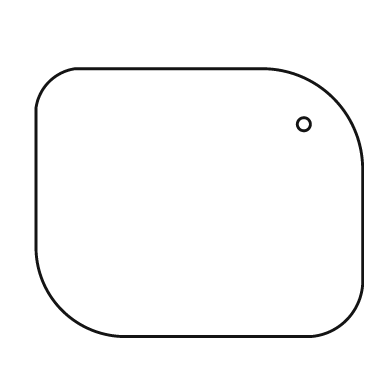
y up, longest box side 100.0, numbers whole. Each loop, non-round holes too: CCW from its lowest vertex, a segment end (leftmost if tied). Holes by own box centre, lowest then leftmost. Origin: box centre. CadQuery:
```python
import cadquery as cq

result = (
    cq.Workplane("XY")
    .moveTo(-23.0, -41.0)
    .lineTo(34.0, -41.0)
    .threePointArc((45.0, -36.0), (50.0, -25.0))
    .lineTo(50.0, 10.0)
    .threePointArc((41.0, 32.0), (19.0, 41.0))
    .lineTo(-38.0, 41.0)
    .threePointArc((-46.0, 37.0), (-50.0, 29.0))
    .lineTo(-50.0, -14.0)
    .threePointArc((-42.0, -33.0), (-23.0, -41.0))
    .close()
    .moveTo(32.0, 24.0)
    .circle(2.0)
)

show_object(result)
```